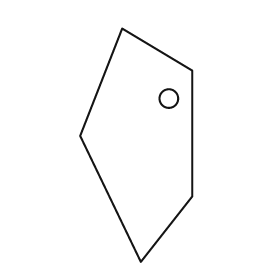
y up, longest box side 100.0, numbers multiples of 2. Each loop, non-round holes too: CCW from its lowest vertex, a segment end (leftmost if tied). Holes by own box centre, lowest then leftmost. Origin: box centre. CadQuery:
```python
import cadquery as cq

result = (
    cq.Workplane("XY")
    .moveTo(2.0, -50.0)
    .lineTo(24.0, -22.0)
    .lineTo(24.0, 32.0)
    .lineTo(-6.0, 50.0)
    .lineTo(-24.0, 4.0)
    .close()
    .moveTo(14.0, 20.0)
    .circle(4.0)
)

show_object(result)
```